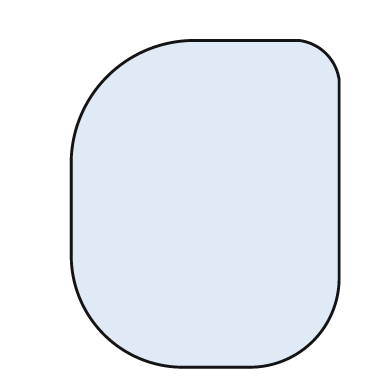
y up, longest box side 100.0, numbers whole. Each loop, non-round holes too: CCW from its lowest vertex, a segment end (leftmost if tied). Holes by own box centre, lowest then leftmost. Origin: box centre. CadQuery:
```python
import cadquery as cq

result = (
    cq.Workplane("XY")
    .moveTo(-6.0, -50.0)
    .lineTo(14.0, -50.0)
    .threePointArc((33.0, -42.0), (41.0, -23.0))
    .lineTo(41.0, 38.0)
    .threePointArc((37.0, 46.0), (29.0, 50.0))
    .lineTo(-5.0, 50.0)
    .threePointArc((-30.0, 39.0), (-41.0, 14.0))
    .lineTo(-41.0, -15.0)
    .threePointArc((-31.0, -40.0), (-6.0, -50.0))
    .close()
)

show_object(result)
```